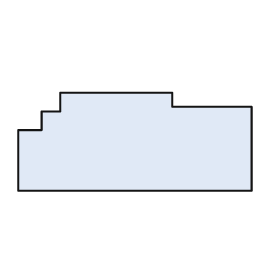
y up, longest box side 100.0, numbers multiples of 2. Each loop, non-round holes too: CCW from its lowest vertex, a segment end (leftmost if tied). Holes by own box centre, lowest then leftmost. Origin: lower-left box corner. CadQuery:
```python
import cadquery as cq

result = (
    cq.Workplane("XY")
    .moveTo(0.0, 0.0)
    .lineTo(100.0, 0.0)
    .lineTo(100.0, 36.0)
    .lineTo(66.0, 36.0)
    .lineTo(66.0, 42.0)
    .lineTo(18.0, 42.0)
    .lineTo(18.0, 34.0)
    .lineTo(10.0, 34.0)
    .lineTo(10.0, 26.0)
    .lineTo(0.0, 26.0)
    .close()
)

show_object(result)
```